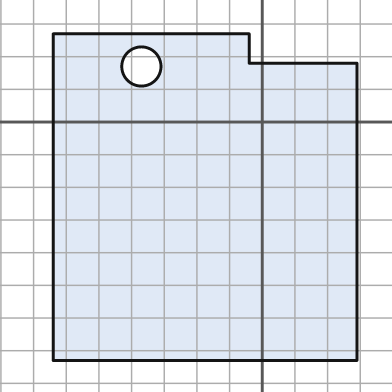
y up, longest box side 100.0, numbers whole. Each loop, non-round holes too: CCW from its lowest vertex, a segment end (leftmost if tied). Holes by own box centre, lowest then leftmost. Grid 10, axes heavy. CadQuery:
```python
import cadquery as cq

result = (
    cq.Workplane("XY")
    .moveTo(-64.0, -73.0)
    .lineTo(29.0, -73.0)
    .lineTo(29.0, 18.0)
    .lineTo(-4.0, 18.0)
    .lineTo(-4.0, 27.0)
    .lineTo(-64.0, 27.0)
    .close()
    .moveTo(-37.0, 17.0)
    .circle(6.0)
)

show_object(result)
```